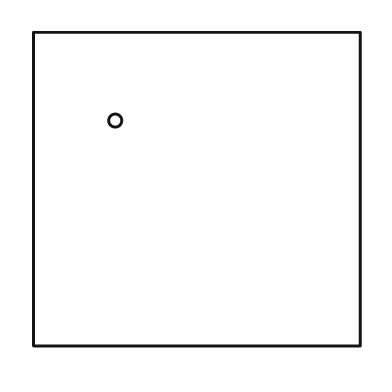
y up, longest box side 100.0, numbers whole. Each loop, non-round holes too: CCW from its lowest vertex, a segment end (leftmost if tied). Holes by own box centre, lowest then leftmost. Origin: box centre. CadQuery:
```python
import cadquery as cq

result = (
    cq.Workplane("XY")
    .moveTo(-50.0, -48.0)
    .lineTo(50.0, -48.0)
    .lineTo(50.0, 48.0)
    .lineTo(-50.0, 48.0)
    .close()
    .moveTo(-25.0, 21.0)
    .circle(2.0)
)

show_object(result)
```